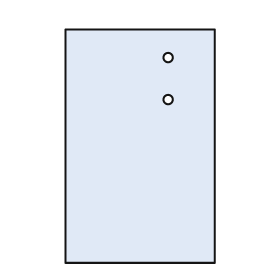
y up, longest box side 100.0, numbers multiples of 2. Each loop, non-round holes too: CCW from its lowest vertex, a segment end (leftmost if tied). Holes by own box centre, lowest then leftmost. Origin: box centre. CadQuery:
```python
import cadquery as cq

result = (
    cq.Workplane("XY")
    .moveTo(-32.0, -50.0)
    .lineTo(32.0, -50.0)
    .lineTo(32.0, 50.0)
    .lineTo(-32.0, 50.0)
    .close()
    .moveTo(12.0, 20.0)
    .circle(2.0)
    .moveTo(12.0, 38.0)
    .circle(2.0)
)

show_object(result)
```